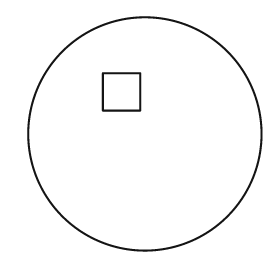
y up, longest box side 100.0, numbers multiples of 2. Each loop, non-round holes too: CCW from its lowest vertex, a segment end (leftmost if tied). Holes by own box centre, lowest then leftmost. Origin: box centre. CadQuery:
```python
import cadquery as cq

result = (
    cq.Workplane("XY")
    .moveTo(0.0, 0.0)
    .circle(50.0)
    .moveTo(-18.0, 10.0)
    .lineTo(-2.0, 10.0)
    .lineTo(-2.0, 26.0)
    .lineTo(-18.0, 26.0)
    .close()
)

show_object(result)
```